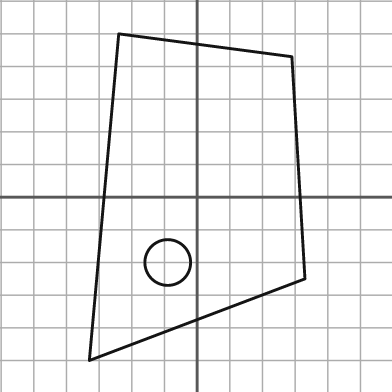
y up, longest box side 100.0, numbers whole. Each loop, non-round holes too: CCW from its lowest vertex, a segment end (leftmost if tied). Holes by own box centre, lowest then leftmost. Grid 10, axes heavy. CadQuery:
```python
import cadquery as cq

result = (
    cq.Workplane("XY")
    .moveTo(-33.0, -50.0)
    .lineTo(33.0, -25.0)
    .lineTo(29.0, 43.0)
    .lineTo(-24.0, 50.0)
    .close()
    .moveTo(-9.0, -20.0)
    .circle(7.0)
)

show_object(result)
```